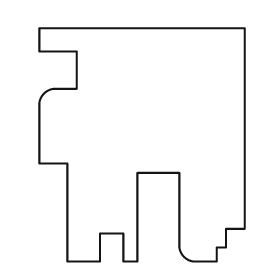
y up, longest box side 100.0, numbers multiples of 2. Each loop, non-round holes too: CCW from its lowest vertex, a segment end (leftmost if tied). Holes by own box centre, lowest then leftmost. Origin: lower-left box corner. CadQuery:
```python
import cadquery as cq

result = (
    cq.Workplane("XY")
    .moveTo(12.0, 0.0)
    .lineTo(26.0, 0.0)
    .lineTo(26.0, 12.0)
    .lineTo(36.0, 12.0)
    .lineTo(36.0, 0.0)
    .lineTo(42.0, 0.0)
    .lineTo(42.0, 38.0)
    .lineTo(60.0, 38.0)
    .lineTo(60.0, 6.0)
    .threePointArc((62.0, 2.0), (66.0, 0.0))
    .lineTo(76.0, 0.0)
    .lineTo(76.0, 6.0)
    .lineTo(80.0, 6.0)
    .lineTo(80.0, 14.0)
    .lineTo(88.0, 14.0)
    .lineTo(88.0, 100.0)
    .lineTo(0.0, 100.0)
    .lineTo(0.0, 90.0)
    .lineTo(16.0, 90.0)
    .lineTo(16.0, 74.0)
    .lineTo(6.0, 74.0)
    .threePointArc((2.0, 72.0), (0.0, 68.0))
    .lineTo(0.0, 42.0)
    .lineTo(12.0, 42.0)
    .close()
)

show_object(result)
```